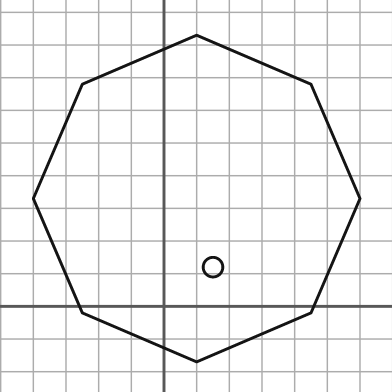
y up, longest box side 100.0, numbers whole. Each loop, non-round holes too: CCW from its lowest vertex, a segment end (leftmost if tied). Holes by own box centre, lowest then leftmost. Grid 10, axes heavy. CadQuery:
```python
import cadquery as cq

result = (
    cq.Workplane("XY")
    .moveTo(10.0, -17.0)
    .lineTo(45.0, -2.0)
    .lineTo(60.0, 33.0)
    .lineTo(45.0, 68.0)
    .lineTo(10.0, 83.0)
    .lineTo(-25.0, 68.0)
    .lineTo(-40.0, 33.0)
    .lineTo(-25.0, -2.0)
    .close()
    .moveTo(15.0, 12.0)
    .circle(3.0)
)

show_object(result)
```